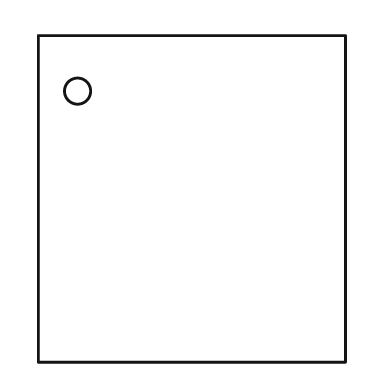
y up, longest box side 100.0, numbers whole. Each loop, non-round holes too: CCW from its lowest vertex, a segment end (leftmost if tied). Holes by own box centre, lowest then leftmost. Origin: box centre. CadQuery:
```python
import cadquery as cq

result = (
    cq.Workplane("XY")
    .moveTo(-47.0, -50.0)
    .lineTo(47.0, -50.0)
    .lineTo(47.0, 50.0)
    .lineTo(-47.0, 50.0)
    .close()
    .moveTo(-35.0, 33.0)
    .circle(4.0)
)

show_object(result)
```